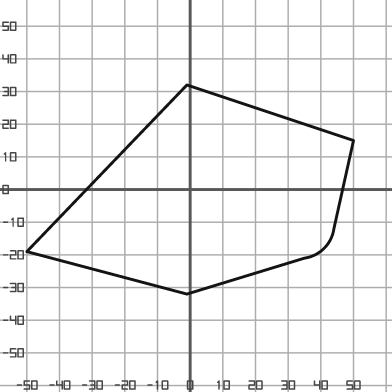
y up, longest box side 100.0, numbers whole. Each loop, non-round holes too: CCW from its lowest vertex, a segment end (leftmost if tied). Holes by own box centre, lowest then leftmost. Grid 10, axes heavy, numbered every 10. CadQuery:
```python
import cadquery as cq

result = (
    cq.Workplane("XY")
    .moveTo(-1.0, -32.0)
    .lineTo(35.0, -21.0)
    .threePointArc((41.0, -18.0), (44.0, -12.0))
    .lineTo(50.0, 15.0)
    .lineTo(-1.0, 32.0)
    .lineTo(-50.0, -19.0)
    .close()
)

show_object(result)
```